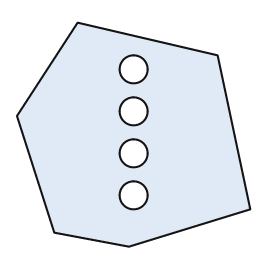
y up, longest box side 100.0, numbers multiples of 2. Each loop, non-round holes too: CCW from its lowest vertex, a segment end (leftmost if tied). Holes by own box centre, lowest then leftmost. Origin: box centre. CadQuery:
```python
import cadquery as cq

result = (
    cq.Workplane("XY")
    .moveTo(-2.0, -48.0)
    .lineTo(50.0, -32.0)
    .lineTo(36.0, 34.0)
    .lineTo(-24.0, 48.0)
    .lineTo(-50.0, 8.0)
    .lineTo(-34.0, -42.0)
    .close()
    .moveTo(0.0, -26.0)
    .circle(6.0)
    .moveTo(0.0, -8.0)
    .circle(6.0)
    .moveTo(0.0, 10.0)
    .circle(6.0)
    .moveTo(0.0, 28.0)
    .circle(6.0)
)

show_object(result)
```